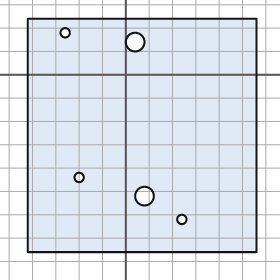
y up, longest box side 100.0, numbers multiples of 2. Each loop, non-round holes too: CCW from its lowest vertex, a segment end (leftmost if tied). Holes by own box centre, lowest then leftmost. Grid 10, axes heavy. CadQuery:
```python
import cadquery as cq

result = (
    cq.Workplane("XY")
    .moveTo(-42.0, -76.0)
    .lineTo(56.0, -76.0)
    .lineTo(56.0, 24.0)
    .lineTo(-42.0, 24.0)
    .close()
    .moveTo(24.0, -62.0)
    .circle(2.0)
    .moveTo(8.0, -52.0)
    .circle(4.0)
    .moveTo(-20.0, -44.0)
    .circle(2.0)
    .moveTo(4.0, 14.0)
    .circle(4.0)
    .moveTo(-26.0, 18.0)
    .circle(2.0)
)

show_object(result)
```